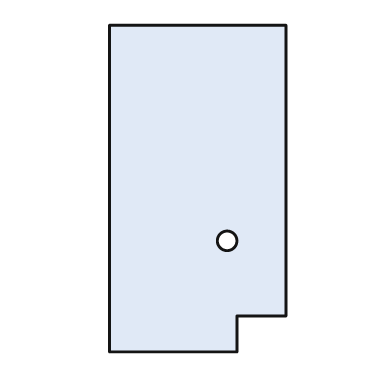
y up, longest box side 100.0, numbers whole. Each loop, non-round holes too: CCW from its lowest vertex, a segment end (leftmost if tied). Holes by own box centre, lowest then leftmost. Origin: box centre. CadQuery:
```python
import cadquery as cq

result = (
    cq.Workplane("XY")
    .moveTo(-27.0, -50.0)
    .lineTo(12.0, -50.0)
    .lineTo(12.0, -39.0)
    .lineTo(27.0, -39.0)
    .lineTo(27.0, 50.0)
    .lineTo(-27.0, 50.0)
    .close()
    .moveTo(9.0, -16.0)
    .circle(3.0)
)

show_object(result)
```